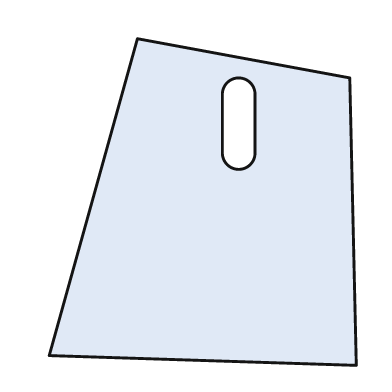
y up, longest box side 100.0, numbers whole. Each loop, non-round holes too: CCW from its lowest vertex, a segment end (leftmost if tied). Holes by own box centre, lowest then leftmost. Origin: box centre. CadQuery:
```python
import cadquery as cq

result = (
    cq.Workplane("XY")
    .moveTo(47.0, -50.0)
    .lineTo(45.0, 38.0)
    .lineTo(-20.0, 50.0)
    .lineTo(-47.0, -47.0)
    .close()
    .moveTo(6.0, 15.0)
    .threePointArc((11.0, 10.0), (16.0, 15.0))
    .lineTo(16.0, 33.0)
    .threePointArc((11.0, 38.0), (6.0, 33.0))
    .close()
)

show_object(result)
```